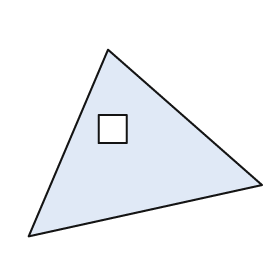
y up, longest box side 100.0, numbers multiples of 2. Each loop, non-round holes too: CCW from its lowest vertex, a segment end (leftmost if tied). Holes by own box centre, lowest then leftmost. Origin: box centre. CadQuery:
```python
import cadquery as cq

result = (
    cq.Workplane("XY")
    .moveTo(-50.0, -40.0)
    .lineTo(50.0, -18.0)
    .lineTo(-16.0, 40.0)
    .close()
    .moveTo(-20.0, 0.0)
    .lineTo(-8.0, 0.0)
    .lineTo(-8.0, 12.0)
    .lineTo(-20.0, 12.0)
    .close()
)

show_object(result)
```